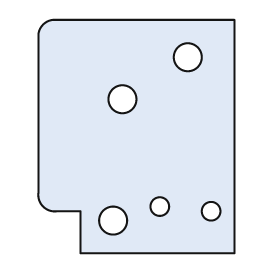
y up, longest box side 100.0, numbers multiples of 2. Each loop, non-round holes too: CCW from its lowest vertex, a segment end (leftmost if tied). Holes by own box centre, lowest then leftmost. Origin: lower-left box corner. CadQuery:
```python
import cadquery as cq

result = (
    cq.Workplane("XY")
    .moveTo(18.0, 0.0)
    .lineTo(84.0, 0.0)
    .lineTo(84.0, 100.0)
    .lineTo(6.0, 100.0)
    .threePointArc((2.0, 98.0), (0.0, 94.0))
    .lineTo(0.0, 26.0)
    .threePointArc((2.0, 20.0), (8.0, 18.0))
    .lineTo(18.0, 18.0)
    .close()
    .moveTo(32.0, 14.0)
    .circle(6.0)
    .moveTo(74.0, 18.0)
    .circle(4.0)
    .moveTo(52.0, 20.0)
    .circle(4.0)
    .moveTo(36.0, 66.0)
    .circle(6.0)
    .moveTo(64.0, 84.0)
    .circle(6.0)
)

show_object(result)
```